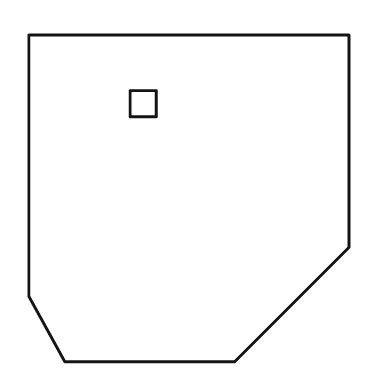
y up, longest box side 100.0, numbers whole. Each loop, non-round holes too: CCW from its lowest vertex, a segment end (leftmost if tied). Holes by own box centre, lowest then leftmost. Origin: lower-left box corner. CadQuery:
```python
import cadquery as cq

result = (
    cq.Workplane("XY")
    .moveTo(11.0, 0.0)
    .lineTo(63.0, 0.0)
    .lineTo(98.0, 35.0)
    .lineTo(98.0, 100.0)
    .lineTo(0.0, 100.0)
    .lineTo(0.0, 20.0)
    .close()
    .moveTo(31.0, 75.0)
    .lineTo(39.0, 75.0)
    .lineTo(39.0, 83.0)
    .lineTo(31.0, 83.0)
    .close()
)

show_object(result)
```